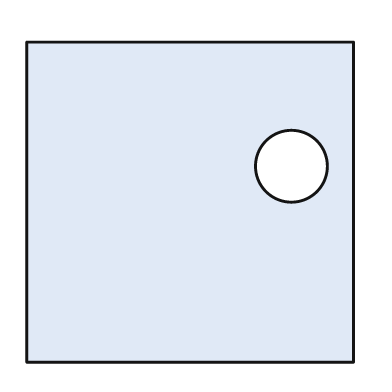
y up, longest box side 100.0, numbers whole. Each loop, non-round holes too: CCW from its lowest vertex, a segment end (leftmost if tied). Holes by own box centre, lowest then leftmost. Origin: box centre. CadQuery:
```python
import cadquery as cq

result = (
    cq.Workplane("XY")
    .moveTo(-50.0, -49.0)
    .lineTo(50.0, -49.0)
    .lineTo(50.0, 49.0)
    .lineTo(-50.0, 49.0)
    .close()
    .moveTo(31.0, 11.0)
    .circle(11.0)
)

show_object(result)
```